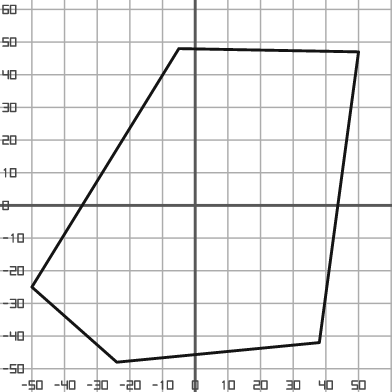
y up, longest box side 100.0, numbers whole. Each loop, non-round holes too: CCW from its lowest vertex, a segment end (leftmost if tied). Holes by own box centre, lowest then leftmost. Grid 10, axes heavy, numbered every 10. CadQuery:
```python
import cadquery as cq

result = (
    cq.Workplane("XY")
    .moveTo(-24.0, -48.0)
    .lineTo(38.0, -42.0)
    .lineTo(50.0, 47.0)
    .lineTo(-5.0, 48.0)
    .lineTo(-50.0, -25.0)
    .close()
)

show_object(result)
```